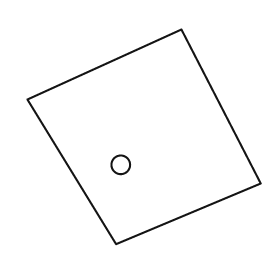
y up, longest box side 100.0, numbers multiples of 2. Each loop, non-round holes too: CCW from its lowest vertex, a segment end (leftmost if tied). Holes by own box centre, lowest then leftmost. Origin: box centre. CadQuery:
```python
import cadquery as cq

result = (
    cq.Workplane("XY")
    .moveTo(-12.0, -46.0)
    .lineTo(50.0, -20.0)
    .lineTo(16.0, 46.0)
    .lineTo(-50.0, 16.0)
    .close()
    .moveTo(-10.0, -12.0)
    .circle(4.0)
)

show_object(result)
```